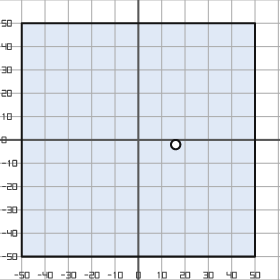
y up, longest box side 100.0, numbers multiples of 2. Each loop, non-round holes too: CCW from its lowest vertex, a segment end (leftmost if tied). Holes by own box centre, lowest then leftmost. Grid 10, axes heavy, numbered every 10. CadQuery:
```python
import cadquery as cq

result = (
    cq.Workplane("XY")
    .moveTo(-50.0, -50.0)
    .lineTo(50.0, -50.0)
    .lineTo(50.0, 50.0)
    .lineTo(-50.0, 50.0)
    .close()
    .moveTo(16.0, -2.0)
    .circle(2.0)
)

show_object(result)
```